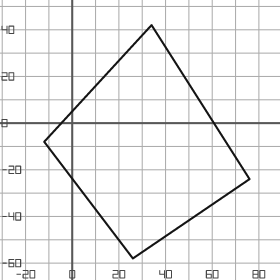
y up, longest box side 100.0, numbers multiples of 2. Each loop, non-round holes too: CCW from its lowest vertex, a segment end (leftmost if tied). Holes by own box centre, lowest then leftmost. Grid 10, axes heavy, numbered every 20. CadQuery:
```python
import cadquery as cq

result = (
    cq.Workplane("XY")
    .moveTo(26.0, -58.0)
    .lineTo(76.0, -24.0)
    .lineTo(34.0, 42.0)
    .lineTo(-12.0, -8.0)
    .close()
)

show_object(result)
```